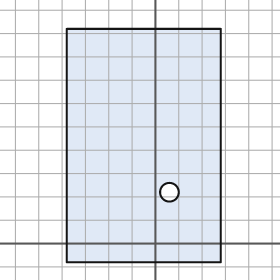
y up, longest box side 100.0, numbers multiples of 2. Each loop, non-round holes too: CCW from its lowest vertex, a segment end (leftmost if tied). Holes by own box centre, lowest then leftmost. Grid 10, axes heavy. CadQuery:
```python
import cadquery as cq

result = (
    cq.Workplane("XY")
    .moveTo(-38.0, -8.0)
    .lineTo(28.0, -8.0)
    .lineTo(28.0, 92.0)
    .lineTo(-38.0, 92.0)
    .close()
    .moveTo(6.0, 22.0)
    .circle(4.0)
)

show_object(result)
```